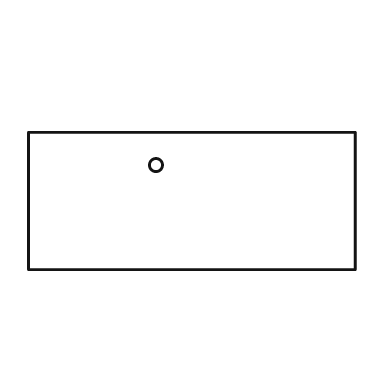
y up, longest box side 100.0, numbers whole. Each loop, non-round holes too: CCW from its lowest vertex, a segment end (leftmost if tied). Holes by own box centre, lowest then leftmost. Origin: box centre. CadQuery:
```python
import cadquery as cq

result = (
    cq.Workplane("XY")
    .moveTo(-50.0, -21.0)
    .lineTo(50.0, -21.0)
    .lineTo(50.0, 21.0)
    .lineTo(-50.0, 21.0)
    .close()
    .moveTo(-11.0, 11.0)
    .circle(2.0)
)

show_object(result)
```